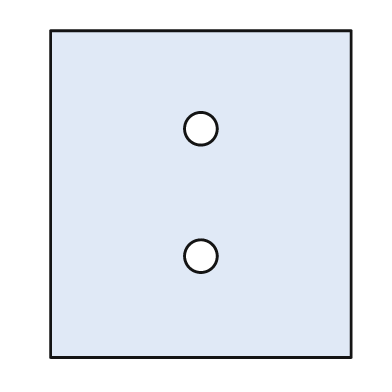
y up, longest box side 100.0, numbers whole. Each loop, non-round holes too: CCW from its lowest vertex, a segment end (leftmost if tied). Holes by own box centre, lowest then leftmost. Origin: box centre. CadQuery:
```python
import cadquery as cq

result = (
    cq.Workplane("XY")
    .moveTo(-46.0, -50.0)
    .lineTo(46.0, -50.0)
    .lineTo(46.0, 50.0)
    .lineTo(-46.0, 50.0)
    .close()
    .moveTo(0.0, -19.0)
    .circle(5.0)
    .moveTo(0.0, 20.0)
    .circle(5.0)
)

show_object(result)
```